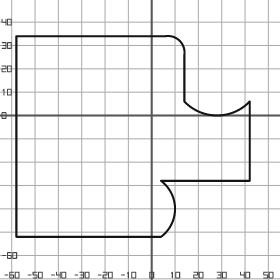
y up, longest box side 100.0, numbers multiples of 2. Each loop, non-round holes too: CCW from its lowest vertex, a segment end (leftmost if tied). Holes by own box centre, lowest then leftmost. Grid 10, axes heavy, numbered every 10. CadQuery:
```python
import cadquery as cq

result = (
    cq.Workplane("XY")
    .moveTo(-58.0, -52.0)
    .lineTo(4.0, -52.0)
    .threePointArc((10.0, -40.0), (4.0, -28.0))
    .lineTo(42.0, -28.0)
    .lineTo(42.0, 6.0)
    .threePointArc((28.0, 0.0), (14.0, 6.0))
    .lineTo(14.0, 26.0)
    .threePointArc((12.0, 32.0), (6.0, 34.0))
    .lineTo(-58.0, 34.0)
    .close()
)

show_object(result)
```